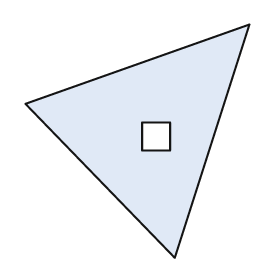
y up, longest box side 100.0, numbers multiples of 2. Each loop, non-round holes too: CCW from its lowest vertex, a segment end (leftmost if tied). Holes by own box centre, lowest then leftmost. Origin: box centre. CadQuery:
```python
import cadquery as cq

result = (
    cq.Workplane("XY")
    .moveTo(16.0, -50.0)
    .lineTo(48.0, 50.0)
    .lineTo(-48.0, 16.0)
    .close()
    .moveTo(2.0, -4.0)
    .lineTo(14.0, -4.0)
    .lineTo(14.0, 8.0)
    .lineTo(2.0, 8.0)
    .close()
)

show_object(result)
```